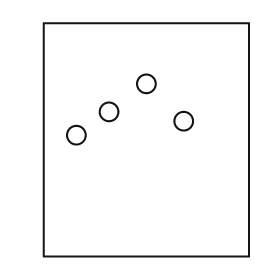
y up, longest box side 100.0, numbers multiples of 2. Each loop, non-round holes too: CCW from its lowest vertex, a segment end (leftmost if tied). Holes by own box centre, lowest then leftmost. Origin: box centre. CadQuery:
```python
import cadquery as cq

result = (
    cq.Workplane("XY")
    .moveTo(-44.0, -50.0)
    .lineTo(44.0, -50.0)
    .lineTo(44.0, 50.0)
    .lineTo(-44.0, 50.0)
    .close()
    .moveTo(-30.0, 2.0)
    .circle(4.0)
    .moveTo(16.0, 8.0)
    .circle(4.0)
    .moveTo(-16.0, 12.0)
    .circle(4.0)
    .moveTo(0.0, 24.0)
    .circle(4.0)
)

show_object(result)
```